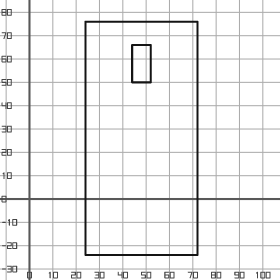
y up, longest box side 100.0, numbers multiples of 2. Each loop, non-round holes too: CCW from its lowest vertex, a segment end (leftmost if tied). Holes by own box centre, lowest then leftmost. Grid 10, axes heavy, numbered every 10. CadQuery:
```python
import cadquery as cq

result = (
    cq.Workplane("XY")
    .moveTo(24.0, -24.0)
    .lineTo(72.0, -24.0)
    .lineTo(72.0, 76.0)
    .lineTo(24.0, 76.0)
    .close()
    .moveTo(44.0, 50.0)
    .lineTo(52.0, 50.0)
    .lineTo(52.0, 66.0)
    .lineTo(44.0, 66.0)
    .close()
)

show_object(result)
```